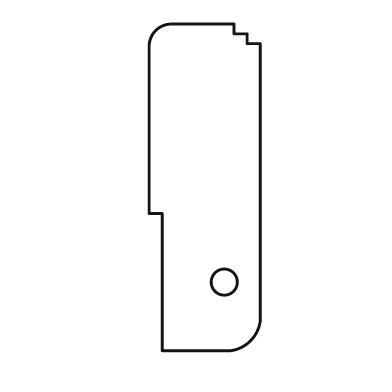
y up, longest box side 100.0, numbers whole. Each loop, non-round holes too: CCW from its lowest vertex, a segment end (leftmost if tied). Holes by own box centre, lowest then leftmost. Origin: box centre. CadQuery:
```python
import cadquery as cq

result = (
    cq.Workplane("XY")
    .moveTo(-13.0, -50.0)
    .lineTo(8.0, -50.0)
    .threePointArc((14.0, -47.0), (17.0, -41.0))
    .lineTo(17.0, 44.0)
    .lineTo(13.0, 44.0)
    .lineTo(13.0, 47.0)
    .lineTo(9.0, 47.0)
    .lineTo(9.0, 50.0)
    .lineTo(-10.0, 50.0)
    .threePointArc((-15.0, 48.0), (-17.0, 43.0))
    .lineTo(-17.0, -8.0)
    .lineTo(-13.0, -8.0)
    .close()
    .moveTo(6.0, -29.0)
    .circle(4.0)
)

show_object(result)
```